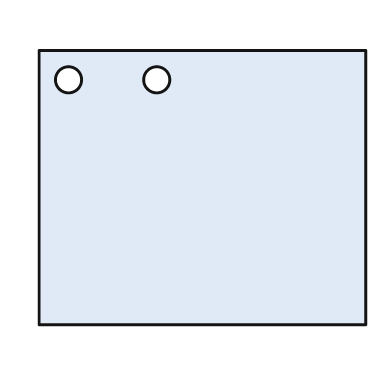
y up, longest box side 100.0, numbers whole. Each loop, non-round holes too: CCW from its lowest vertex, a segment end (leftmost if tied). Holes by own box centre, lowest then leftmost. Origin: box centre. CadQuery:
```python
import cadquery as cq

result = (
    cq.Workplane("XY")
    .moveTo(-50.0, -42.0)
    .lineTo(50.0, -42.0)
    .lineTo(50.0, 42.0)
    .lineTo(-50.0, 42.0)
    .close()
    .moveTo(-41.0, 33.0)
    .circle(4.0)
    .moveTo(-14.0, 33.0)
    .circle(4.0)
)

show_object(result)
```